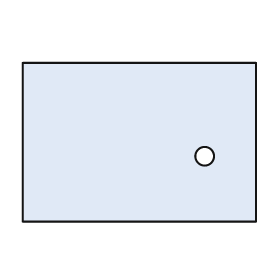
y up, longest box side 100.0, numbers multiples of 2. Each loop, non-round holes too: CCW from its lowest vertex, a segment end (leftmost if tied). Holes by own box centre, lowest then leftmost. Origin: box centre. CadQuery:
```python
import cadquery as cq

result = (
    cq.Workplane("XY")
    .moveTo(-50.0, -34.0)
    .lineTo(50.0, -34.0)
    .lineTo(50.0, 34.0)
    .lineTo(-50.0, 34.0)
    .close()
    .moveTo(28.0, -6.0)
    .circle(4.0)
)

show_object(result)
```